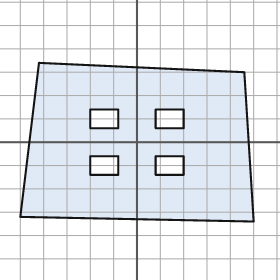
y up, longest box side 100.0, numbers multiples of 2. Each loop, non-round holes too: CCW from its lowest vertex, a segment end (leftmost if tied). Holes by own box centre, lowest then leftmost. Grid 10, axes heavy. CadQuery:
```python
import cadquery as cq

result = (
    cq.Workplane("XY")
    .moveTo(50.0, -34.0)
    .lineTo(46.0, 30.0)
    .lineTo(-42.0, 34.0)
    .lineTo(-50.0, -32.0)
    .close()
    .moveTo(-20.0, -14.0)
    .lineTo(-8.0, -14.0)
    .lineTo(-8.0, -6.0)
    .lineTo(-20.0, -6.0)
    .close()
    .moveTo(8.0, -14.0)
    .lineTo(20.0, -14.0)
    .lineTo(20.0, -6.0)
    .lineTo(8.0, -6.0)
    .close()
    .moveTo(-20.0, 6.0)
    .lineTo(-8.0, 6.0)
    .lineTo(-8.0, 14.0)
    .lineTo(-20.0, 14.0)
    .close()
    .moveTo(8.0, 6.0)
    .lineTo(20.0, 6.0)
    .lineTo(20.0, 14.0)
    .lineTo(8.0, 14.0)
    .close()
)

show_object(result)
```